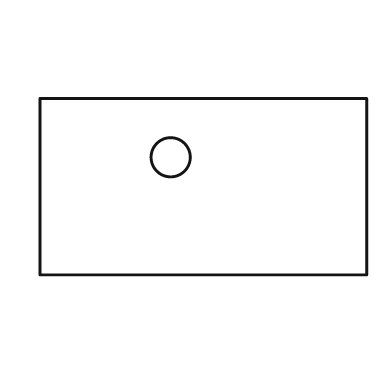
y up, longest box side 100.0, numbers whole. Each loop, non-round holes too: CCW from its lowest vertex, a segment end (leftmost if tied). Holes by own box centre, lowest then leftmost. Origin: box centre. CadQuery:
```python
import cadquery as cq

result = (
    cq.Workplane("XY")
    .moveTo(-50.0, -27.0)
    .lineTo(50.0, -27.0)
    .lineTo(50.0, 27.0)
    .lineTo(-50.0, 27.0)
    .close()
    .moveTo(-10.0, 9.0)
    .circle(6.0)
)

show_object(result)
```